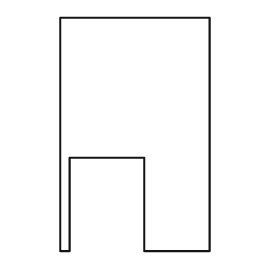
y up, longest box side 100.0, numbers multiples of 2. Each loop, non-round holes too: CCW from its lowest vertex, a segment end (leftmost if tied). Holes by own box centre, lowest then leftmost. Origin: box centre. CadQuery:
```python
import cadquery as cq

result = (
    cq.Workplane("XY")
    .moveTo(-32.0, -50.0)
    .lineTo(-28.0, -50.0)
    .lineTo(-28.0, -10.0)
    .lineTo(4.0, -10.0)
    .lineTo(4.0, -50.0)
    .lineTo(32.0, -50.0)
    .lineTo(32.0, 50.0)
    .lineTo(-32.0, 50.0)
    .close()
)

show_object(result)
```